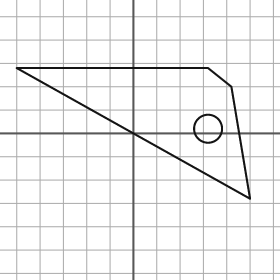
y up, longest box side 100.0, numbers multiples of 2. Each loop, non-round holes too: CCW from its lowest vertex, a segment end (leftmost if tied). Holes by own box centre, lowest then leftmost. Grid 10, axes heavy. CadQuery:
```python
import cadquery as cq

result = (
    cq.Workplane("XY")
    .moveTo(50.0, -28.0)
    .lineTo(42.0, 20.0)
    .lineTo(32.0, 28.0)
    .lineTo(-50.0, 28.0)
    .close()
    .moveTo(32.0, 2.0)
    .circle(6.0)
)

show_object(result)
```